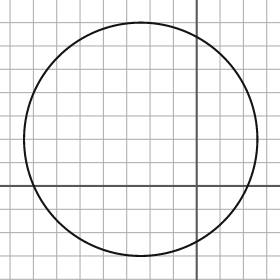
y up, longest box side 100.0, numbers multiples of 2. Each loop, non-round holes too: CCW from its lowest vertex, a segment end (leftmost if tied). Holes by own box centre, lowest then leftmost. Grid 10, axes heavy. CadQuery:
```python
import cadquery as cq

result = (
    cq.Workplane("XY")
    .moveTo(-24.0, 20.0)
    .circle(50.0)
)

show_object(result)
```